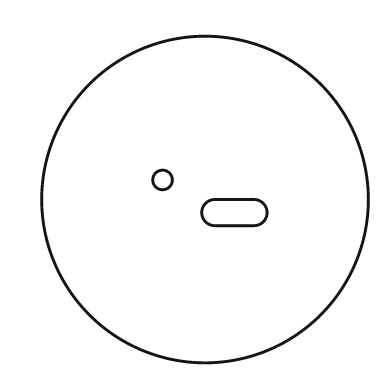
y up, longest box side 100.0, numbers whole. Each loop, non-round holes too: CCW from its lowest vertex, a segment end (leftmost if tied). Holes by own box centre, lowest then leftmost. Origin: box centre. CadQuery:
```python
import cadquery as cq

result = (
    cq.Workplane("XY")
    .moveTo(0.0, 0.0)
    .circle(50.0)
    .moveTo(3.0, -8.0)
    .lineTo(15.0, -8.0)
    .threePointArc((19.0, -4.0), (15.0, 0.0))
    .lineTo(3.0, 0.0)
    .threePointArc((-1.0, -4.0), (3.0, -8.0))
    .close()
    .moveTo(-13.0, 6.0)
    .circle(3.0)
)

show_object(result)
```